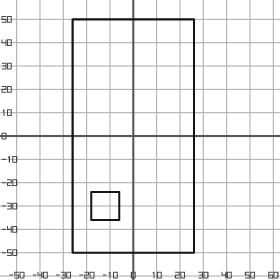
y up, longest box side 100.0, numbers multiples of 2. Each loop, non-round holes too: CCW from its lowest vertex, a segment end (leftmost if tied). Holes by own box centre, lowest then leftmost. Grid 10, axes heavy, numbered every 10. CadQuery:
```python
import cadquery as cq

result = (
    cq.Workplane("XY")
    .moveTo(-26.0, -50.0)
    .lineTo(26.0, -50.0)
    .lineTo(26.0, 50.0)
    .lineTo(-26.0, 50.0)
    .close()
    .moveTo(-18.0, -36.0)
    .lineTo(-6.0, -36.0)
    .lineTo(-6.0, -24.0)
    .lineTo(-18.0, -24.0)
    .close()
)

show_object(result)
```